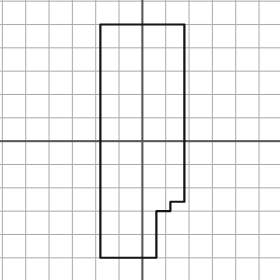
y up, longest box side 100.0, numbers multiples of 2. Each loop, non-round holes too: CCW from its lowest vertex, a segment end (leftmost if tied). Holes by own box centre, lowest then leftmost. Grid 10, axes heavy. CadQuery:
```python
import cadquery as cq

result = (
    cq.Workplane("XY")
    .moveTo(-18.0, -50.0)
    .lineTo(6.0, -50.0)
    .lineTo(6.0, -30.0)
    .lineTo(12.0, -30.0)
    .lineTo(12.0, -26.0)
    .lineTo(18.0, -26.0)
    .lineTo(18.0, 50.0)
    .lineTo(-18.0, 50.0)
    .close()
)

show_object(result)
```